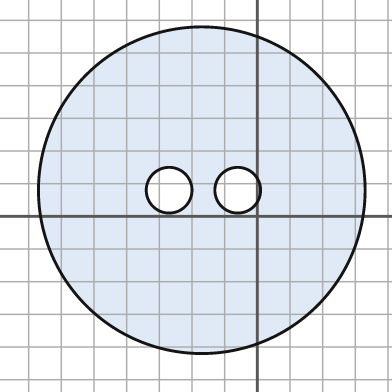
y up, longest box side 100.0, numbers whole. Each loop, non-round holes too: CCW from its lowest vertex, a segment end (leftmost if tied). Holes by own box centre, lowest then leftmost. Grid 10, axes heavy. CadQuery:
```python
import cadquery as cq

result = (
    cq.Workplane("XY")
    .moveTo(-17.0, 8.0)
    .circle(50.0)
    .moveTo(-27.0, 8.0)
    .circle(7.0)
    .moveTo(-6.0, 8.0)
    .circle(7.0)
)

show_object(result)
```